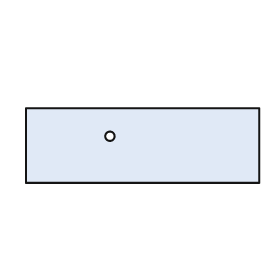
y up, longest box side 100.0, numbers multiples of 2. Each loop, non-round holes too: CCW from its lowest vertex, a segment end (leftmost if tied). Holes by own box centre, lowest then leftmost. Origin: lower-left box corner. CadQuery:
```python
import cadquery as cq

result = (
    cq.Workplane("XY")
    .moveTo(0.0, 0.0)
    .lineTo(100.0, 0.0)
    .lineTo(100.0, 32.0)
    .lineTo(0.0, 32.0)
    .close()
    .moveTo(36.0, 20.0)
    .circle(2.0)
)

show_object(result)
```